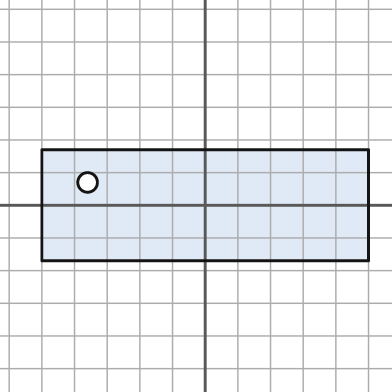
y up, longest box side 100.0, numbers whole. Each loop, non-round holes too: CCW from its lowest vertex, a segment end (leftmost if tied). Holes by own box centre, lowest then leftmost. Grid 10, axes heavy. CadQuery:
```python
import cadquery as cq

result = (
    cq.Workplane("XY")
    .moveTo(-50.0, -17.0)
    .lineTo(50.0, -17.0)
    .lineTo(50.0, 17.0)
    .lineTo(-50.0, 17.0)
    .close()
    .moveTo(-36.0, 7.0)
    .circle(3.0)
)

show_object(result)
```